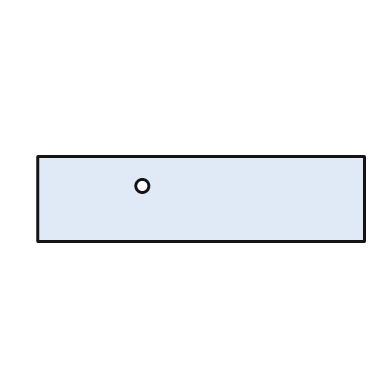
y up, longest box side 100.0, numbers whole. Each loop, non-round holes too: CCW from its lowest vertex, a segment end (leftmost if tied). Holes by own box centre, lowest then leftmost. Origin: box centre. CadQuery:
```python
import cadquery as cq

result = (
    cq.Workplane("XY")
    .moveTo(-50.0, -13.0)
    .lineTo(50.0, -13.0)
    .lineTo(50.0, 13.0)
    .lineTo(-50.0, 13.0)
    .close()
    .moveTo(-18.0, 4.0)
    .circle(2.0)
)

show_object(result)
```